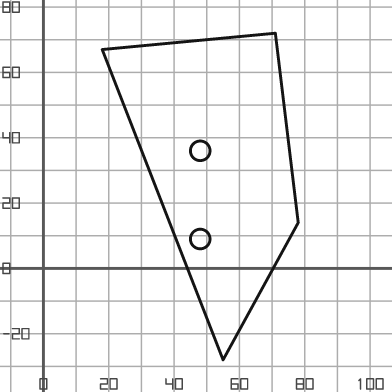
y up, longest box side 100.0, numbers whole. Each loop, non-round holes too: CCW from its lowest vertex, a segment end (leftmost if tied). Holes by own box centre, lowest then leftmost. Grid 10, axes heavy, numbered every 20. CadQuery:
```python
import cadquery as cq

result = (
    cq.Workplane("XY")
    .moveTo(55.0, -28.0)
    .lineTo(78.0, 14.0)
    .lineTo(71.0, 72.0)
    .lineTo(18.0, 67.0)
    .close()
    .moveTo(48.0, 9.0)
    .circle(3.0)
    .moveTo(48.0, 36.0)
    .circle(3.0)
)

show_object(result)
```